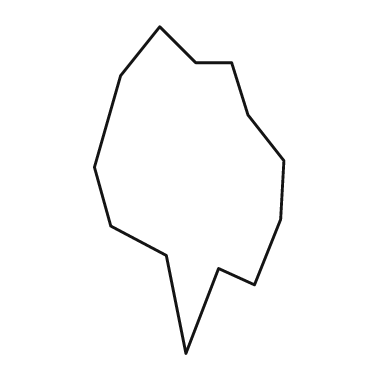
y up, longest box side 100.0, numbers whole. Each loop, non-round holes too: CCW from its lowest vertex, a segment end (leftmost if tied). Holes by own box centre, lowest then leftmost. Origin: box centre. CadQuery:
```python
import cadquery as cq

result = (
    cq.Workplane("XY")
    .moveTo(-1.0, -50.0)
    .lineTo(9.0, -24.0)
    .lineTo(20.0, -29.0)
    .lineTo(28.0, -9.0)
    .lineTo(29.0, 9.0)
    .lineTo(18.0, 23.0)
    .lineTo(13.0, 39.0)
    .lineTo(2.0, 39.0)
    .lineTo(-9.0, 50.0)
    .lineTo(-21.0, 35.0)
    .lineTo(-29.0, 7.0)
    .lineTo(-24.0, -11.0)
    .lineTo(-7.0, -20.0)
    .close()
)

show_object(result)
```